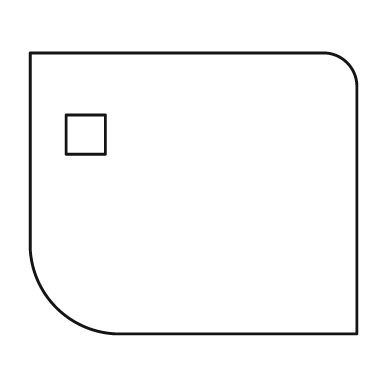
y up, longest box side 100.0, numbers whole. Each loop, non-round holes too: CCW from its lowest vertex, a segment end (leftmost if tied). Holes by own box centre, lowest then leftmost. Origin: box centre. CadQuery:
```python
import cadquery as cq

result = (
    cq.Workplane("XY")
    .moveTo(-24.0, -43.0)
    .lineTo(50.0, -43.0)
    .lineTo(50.0, 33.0)
    .threePointArc((47.0, 40.0), (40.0, 43.0))
    .lineTo(-50.0, 43.0)
    .lineTo(-50.0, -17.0)
    .threePointArc((-42.0, -35.0), (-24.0, -43.0))
    .close()
    .moveTo(-39.0, 12.0)
    .lineTo(-27.0, 12.0)
    .lineTo(-27.0, 24.0)
    .lineTo(-39.0, 24.0)
    .close()
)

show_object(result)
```